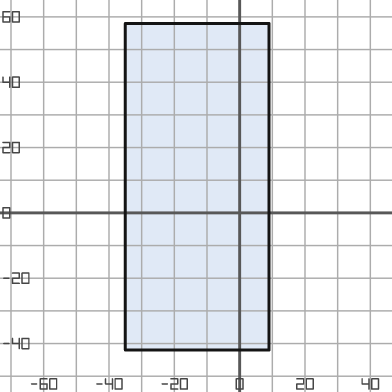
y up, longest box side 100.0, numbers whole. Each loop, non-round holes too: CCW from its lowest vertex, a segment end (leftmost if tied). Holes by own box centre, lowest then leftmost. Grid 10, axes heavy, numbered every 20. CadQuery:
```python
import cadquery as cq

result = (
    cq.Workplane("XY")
    .moveTo(-35.0, -42.0)
    .lineTo(9.0, -42.0)
    .lineTo(9.0, 58.0)
    .lineTo(-35.0, 58.0)
    .close()
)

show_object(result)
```